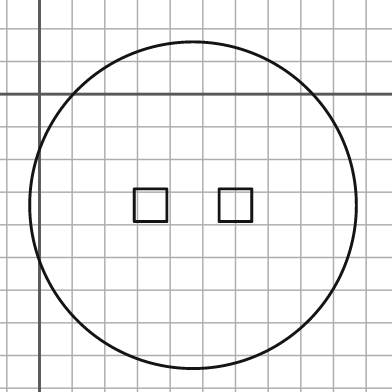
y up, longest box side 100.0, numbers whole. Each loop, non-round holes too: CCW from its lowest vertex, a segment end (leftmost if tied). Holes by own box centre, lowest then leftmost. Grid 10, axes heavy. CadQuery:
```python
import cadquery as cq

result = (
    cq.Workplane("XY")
    .moveTo(47.0, -34.0)
    .circle(50.0)
    .moveTo(29.0, -39.0)
    .lineTo(39.0, -39.0)
    .lineTo(39.0, -29.0)
    .lineTo(29.0, -29.0)
    .close()
    .moveTo(55.0, -39.0)
    .lineTo(65.0, -39.0)
    .lineTo(65.0, -29.0)
    .lineTo(55.0, -29.0)
    .close()
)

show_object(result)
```